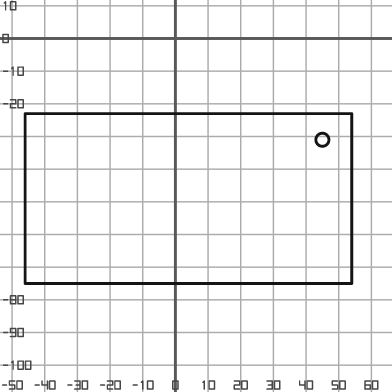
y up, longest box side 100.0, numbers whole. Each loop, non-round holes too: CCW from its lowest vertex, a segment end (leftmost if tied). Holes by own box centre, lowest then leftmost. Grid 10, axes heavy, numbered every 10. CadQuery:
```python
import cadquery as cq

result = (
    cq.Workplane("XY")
    .moveTo(-46.0, -75.0)
    .lineTo(54.0, -75.0)
    .lineTo(54.0, -23.0)
    .lineTo(-46.0, -23.0)
    .close()
    .moveTo(45.0, -31.0)
    .circle(2.0)
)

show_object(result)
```